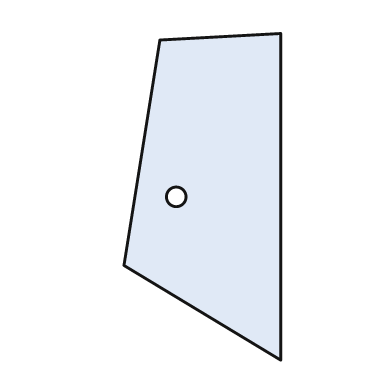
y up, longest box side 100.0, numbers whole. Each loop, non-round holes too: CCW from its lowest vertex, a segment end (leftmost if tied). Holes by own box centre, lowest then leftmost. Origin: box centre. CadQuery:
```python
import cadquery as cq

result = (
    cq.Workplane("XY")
    .moveTo(24.0, -50.0)
    .lineTo(24.0, 50.0)
    .lineTo(-13.0, 48.0)
    .lineTo(-24.0, -21.0)
    .close()
    .moveTo(-8.0, 0.0)
    .circle(3.0)
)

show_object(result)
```